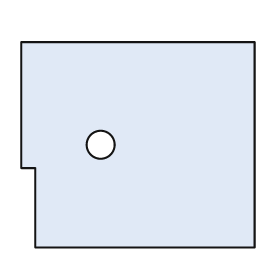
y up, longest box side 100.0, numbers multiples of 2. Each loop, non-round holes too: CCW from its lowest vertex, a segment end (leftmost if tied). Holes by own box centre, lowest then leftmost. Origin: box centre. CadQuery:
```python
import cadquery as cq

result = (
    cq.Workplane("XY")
    .moveTo(-44.0, -44.0)
    .lineTo(50.0, -44.0)
    .lineTo(50.0, 44.0)
    .lineTo(-50.0, 44.0)
    .lineTo(-50.0, -10.0)
    .lineTo(-44.0, -10.0)
    .close()
    .moveTo(-16.0, 0.0)
    .circle(6.0)
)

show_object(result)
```